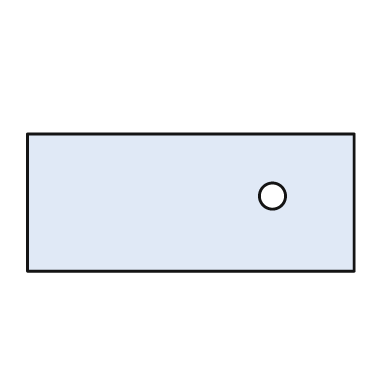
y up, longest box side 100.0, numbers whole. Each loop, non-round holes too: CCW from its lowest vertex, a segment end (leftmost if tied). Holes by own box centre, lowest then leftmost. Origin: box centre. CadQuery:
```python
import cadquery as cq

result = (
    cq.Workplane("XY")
    .moveTo(-50.0, -21.0)
    .lineTo(50.0, -21.0)
    .lineTo(50.0, 21.0)
    .lineTo(-50.0, 21.0)
    .close()
    .moveTo(25.0, 2.0)
    .circle(4.0)
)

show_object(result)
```